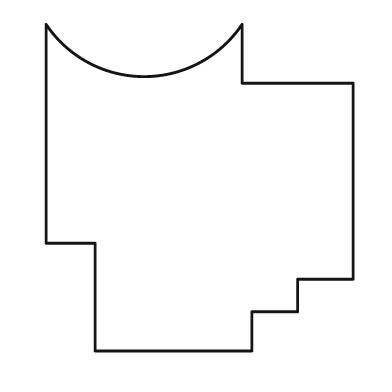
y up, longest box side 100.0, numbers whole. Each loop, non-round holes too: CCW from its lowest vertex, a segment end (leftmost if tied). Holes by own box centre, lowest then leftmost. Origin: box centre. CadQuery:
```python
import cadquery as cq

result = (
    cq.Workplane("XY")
    .moveTo(-32.0, -50.0)
    .lineTo(16.0, -50.0)
    .lineTo(16.0, -38.0)
    .lineTo(30.0, -38.0)
    .lineTo(30.0, -28.0)
    .lineTo(47.0, -28.0)
    .lineTo(47.0, 32.0)
    .lineTo(13.0, 32.0)
    .lineTo(13.0, 50.0)
    .threePointArc((-17.0, 34.0), (-47.0, 50.0))
    .lineTo(-47.0, -17.0)
    .lineTo(-32.0, -17.0)
    .close()
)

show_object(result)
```